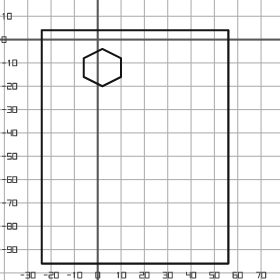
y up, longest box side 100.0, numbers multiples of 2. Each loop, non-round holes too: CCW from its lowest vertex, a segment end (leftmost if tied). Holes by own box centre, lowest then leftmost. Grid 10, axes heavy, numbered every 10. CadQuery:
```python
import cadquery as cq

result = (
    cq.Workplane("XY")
    .moveTo(-24.0, -96.0)
    .lineTo(56.0, -96.0)
    .lineTo(56.0, 4.0)
    .lineTo(-24.0, 4.0)
    .close()
    .moveTo(2.0, -20.0)
    .lineTo(10.0, -16.0)
    .lineTo(10.0, -8.0)
    .lineTo(2.0, -4.0)
    .lineTo(-6.0, -8.0)
    .lineTo(-6.0, -16.0)
    .close()
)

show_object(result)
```